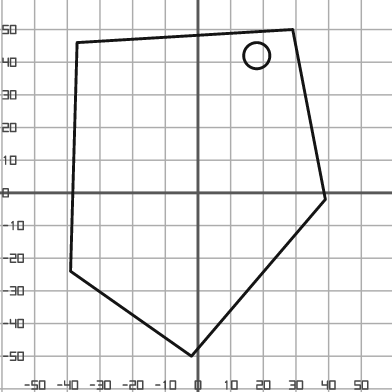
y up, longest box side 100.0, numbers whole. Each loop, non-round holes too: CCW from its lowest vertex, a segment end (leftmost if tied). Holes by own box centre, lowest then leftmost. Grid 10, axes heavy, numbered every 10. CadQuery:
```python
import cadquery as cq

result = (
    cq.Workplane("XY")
    .moveTo(-2.0, -50.0)
    .lineTo(39.0, -2.0)
    .lineTo(29.0, 50.0)
    .lineTo(-37.0, 46.0)
    .lineTo(-39.0, -24.0)
    .close()
    .moveTo(18.0, 42.0)
    .circle(4.0)
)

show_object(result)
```